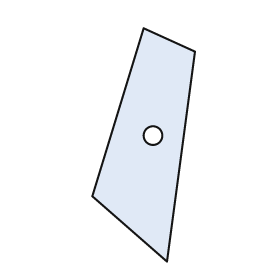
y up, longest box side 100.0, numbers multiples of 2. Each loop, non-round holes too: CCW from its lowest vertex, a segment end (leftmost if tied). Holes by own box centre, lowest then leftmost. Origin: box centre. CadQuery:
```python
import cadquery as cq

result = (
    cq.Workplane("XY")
    .moveTo(10.0, -50.0)
    .lineTo(22.0, 40.0)
    .lineTo(0.0, 50.0)
    .lineTo(-22.0, -22.0)
    .close()
    .moveTo(4.0, 4.0)
    .circle(4.0)
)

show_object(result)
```